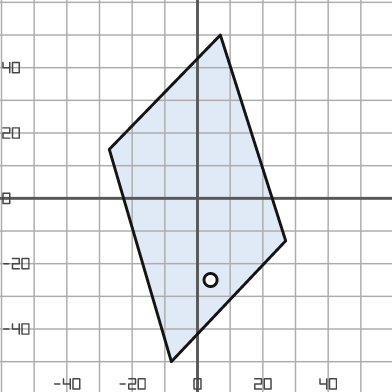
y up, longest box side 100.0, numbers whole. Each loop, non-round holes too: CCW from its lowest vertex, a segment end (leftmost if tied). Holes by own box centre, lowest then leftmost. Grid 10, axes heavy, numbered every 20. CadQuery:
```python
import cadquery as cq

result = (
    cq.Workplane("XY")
    .moveTo(-8.0, -50.0)
    .lineTo(27.0, -13.0)
    .lineTo(7.0, 50.0)
    .lineTo(-27.0, 15.0)
    .close()
    .moveTo(4.0, -25.0)
    .circle(2.0)
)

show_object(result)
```